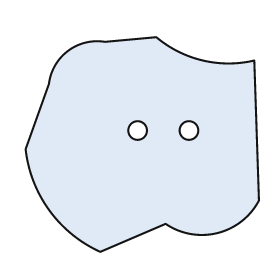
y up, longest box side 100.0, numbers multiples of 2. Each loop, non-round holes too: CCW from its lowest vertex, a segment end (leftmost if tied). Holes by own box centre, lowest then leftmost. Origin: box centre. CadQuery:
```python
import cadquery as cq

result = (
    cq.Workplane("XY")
    .moveTo(-18.0, -46.0)
    .lineTo(10.0, -34.0)
    .threePointArc((32.0, -38.0), (50.0, -24.0))
    .lineTo(48.0, 36.0)
    .threePointArc((26.0, 36.0), (6.0, 46.0))
    .lineTo(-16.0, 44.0)
    .threePointArc((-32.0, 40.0), (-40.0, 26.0))
    .lineTo(-50.0, -2.0)
    .threePointArc((-40.0, -28.0), (-18.0, -46.0))
    .close()
    .moveTo(-2.0, 6.0)
    .circle(4.0)
    .moveTo(20.0, 6.0)
    .circle(4.0)
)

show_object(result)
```